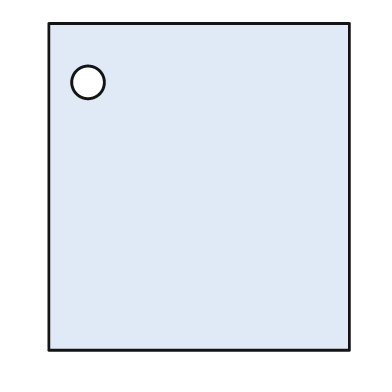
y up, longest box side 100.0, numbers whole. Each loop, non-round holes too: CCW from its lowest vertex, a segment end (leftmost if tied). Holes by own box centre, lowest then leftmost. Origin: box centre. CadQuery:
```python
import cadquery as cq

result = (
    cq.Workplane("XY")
    .moveTo(-46.0, -50.0)
    .lineTo(46.0, -50.0)
    .lineTo(46.0, 50.0)
    .lineTo(-46.0, 50.0)
    .close()
    .moveTo(-34.0, 32.0)
    .circle(5.0)
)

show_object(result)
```